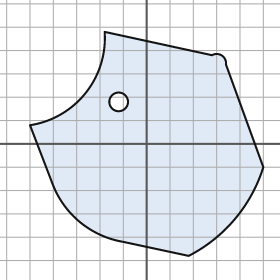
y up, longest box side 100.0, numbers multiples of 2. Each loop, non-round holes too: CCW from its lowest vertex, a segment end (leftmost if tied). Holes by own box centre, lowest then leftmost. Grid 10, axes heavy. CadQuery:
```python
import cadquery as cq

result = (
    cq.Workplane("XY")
    .moveTo(18.0, -48.0)
    .threePointArc((38.0, -32.0), (50.0, -10.0))
    .lineTo(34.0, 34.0)
    .threePointArc((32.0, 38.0), (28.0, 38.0))
    .lineTo(-18.0, 48.0)
    .threePointArc((-26.0, 22.0), (-50.0, 8.0))
    .lineTo(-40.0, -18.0)
    .threePointArc((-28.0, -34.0), (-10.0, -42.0))
    .close()
    .moveTo(-12.0, 18.0)
    .circle(4.0)
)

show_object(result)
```